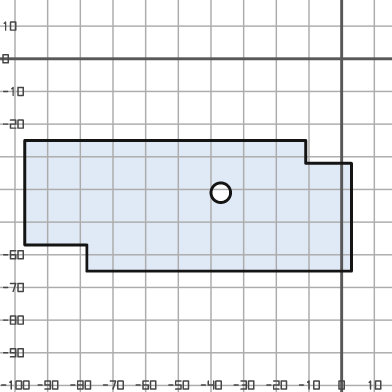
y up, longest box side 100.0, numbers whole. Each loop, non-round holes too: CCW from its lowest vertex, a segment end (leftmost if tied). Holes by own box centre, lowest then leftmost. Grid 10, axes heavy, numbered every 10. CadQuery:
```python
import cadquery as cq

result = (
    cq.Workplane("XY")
    .moveTo(-78.0, -65.0)
    .lineTo(3.0, -65.0)
    .lineTo(3.0, -32.0)
    .lineTo(-11.0, -32.0)
    .lineTo(-11.0, -25.0)
    .lineTo(-97.0, -25.0)
    .lineTo(-97.0, -57.0)
    .lineTo(-78.0, -57.0)
    .close()
    .moveTo(-37.0, -41.0)
    .circle(3.0)
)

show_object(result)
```